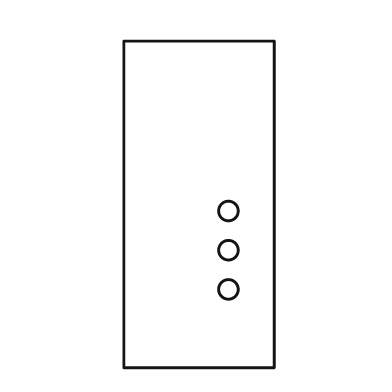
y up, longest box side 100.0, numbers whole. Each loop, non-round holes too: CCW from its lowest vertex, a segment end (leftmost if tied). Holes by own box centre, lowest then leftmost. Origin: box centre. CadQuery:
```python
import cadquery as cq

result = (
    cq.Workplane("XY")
    .moveTo(-23.0, -50.0)
    .lineTo(23.0, -50.0)
    .lineTo(23.0, 50.0)
    .lineTo(-23.0, 50.0)
    .close()
    .moveTo(9.0, -26.0)
    .circle(3.0)
    .moveTo(9.0, -14.0)
    .circle(3.0)
    .moveTo(9.0, -2.0)
    .circle(3.0)
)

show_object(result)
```